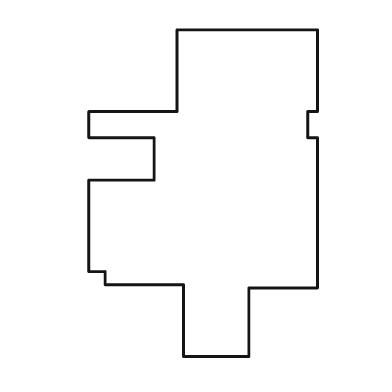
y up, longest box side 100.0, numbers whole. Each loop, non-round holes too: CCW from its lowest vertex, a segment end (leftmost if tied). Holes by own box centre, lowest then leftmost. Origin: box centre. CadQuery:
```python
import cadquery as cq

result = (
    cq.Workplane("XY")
    .moveTo(-6.0, -50.0)
    .lineTo(14.0, -50.0)
    .lineTo(14.0, -29.0)
    .lineTo(35.0, -29.0)
    .lineTo(35.0, 17.0)
    .lineTo(32.0, 17.0)
    .lineTo(32.0, 25.0)
    .lineTo(35.0, 25.0)
    .lineTo(35.0, 50.0)
    .lineTo(-8.0, 50.0)
    .lineTo(-8.0, 25.0)
    .lineTo(-35.0, 25.0)
    .lineTo(-35.0, 17.0)
    .lineTo(-15.0, 17.0)
    .lineTo(-15.0, 4.0)
    .lineTo(-35.0, 4.0)
    .lineTo(-35.0, -24.0)
    .lineTo(-30.0, -24.0)
    .lineTo(-30.0, -28.0)
    .lineTo(-6.0, -28.0)
    .close()
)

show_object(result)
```